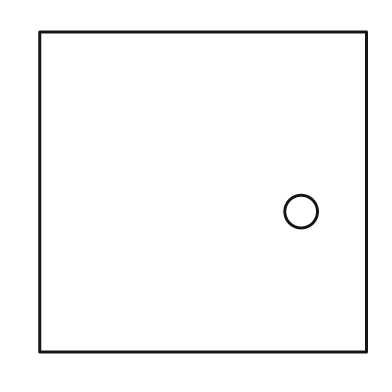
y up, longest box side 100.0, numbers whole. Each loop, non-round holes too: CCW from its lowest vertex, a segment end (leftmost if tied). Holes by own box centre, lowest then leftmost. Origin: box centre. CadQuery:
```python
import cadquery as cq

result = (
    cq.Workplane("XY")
    .moveTo(-50.0, -49.0)
    .lineTo(50.0, -49.0)
    .lineTo(50.0, 49.0)
    .lineTo(-50.0, 49.0)
    .close()
    .moveTo(30.0, -6.0)
    .circle(5.0)
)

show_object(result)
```